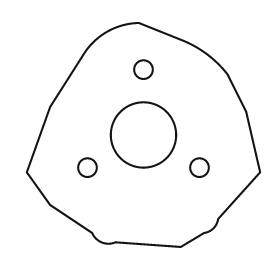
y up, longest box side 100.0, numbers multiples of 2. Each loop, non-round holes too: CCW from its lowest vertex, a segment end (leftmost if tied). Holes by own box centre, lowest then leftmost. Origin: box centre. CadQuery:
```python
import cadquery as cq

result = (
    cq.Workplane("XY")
    .moveTo(16.0, -48.0)
    .lineTo(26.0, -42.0)
    .threePointArc((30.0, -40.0), (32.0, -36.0))
    .lineTo(50.0, -16.0)
    .lineTo(44.0, 10.0)
    .lineTo(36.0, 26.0)
    .threePointArc((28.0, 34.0), (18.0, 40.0))
    .lineTo(-2.0, 48.0)
    .threePointArc((-16.0, 44.0), (-26.0, 34.0))
    .lineTo(-40.0, 12.0)
    .lineTo(-50.0, -16.0)
    .lineTo(-40.0, -30.0)
    .lineTo(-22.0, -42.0)
    .threePointArc((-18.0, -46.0), (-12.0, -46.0))
    .close()
    .moveTo(-24.0, -14.0)
    .circle(4.0)
    .moveTo(24.0, -14.0)
    .circle(4.0)
    .moveTo(0.0, 0.0)
    .circle(14.0)
    .moveTo(0.0, 28.0)
    .circle(4.0)
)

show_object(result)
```